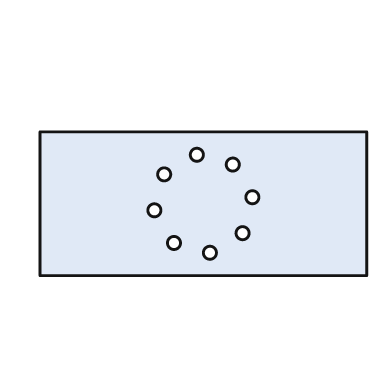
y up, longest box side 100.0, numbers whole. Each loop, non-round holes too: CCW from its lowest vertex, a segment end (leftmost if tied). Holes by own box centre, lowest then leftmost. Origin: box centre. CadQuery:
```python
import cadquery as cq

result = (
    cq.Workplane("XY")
    .moveTo(-50.0, -22.0)
    .lineTo(50.0, -22.0)
    .lineTo(50.0, 22.0)
    .lineTo(-50.0, 22.0)
    .close()
    .moveTo(2.0, -15.0)
    .circle(2.0)
    .moveTo(-9.0, -12.0)
    .circle(2.0)
    .moveTo(12.0, -9.0)
    .circle(2.0)
    .moveTo(-15.0, -2.0)
    .circle(2.0)
    .moveTo(15.0, 2.0)
    .circle(2.0)
    .moveTo(-12.0, 9.0)
    .circle(2.0)
    .moveTo(9.0, 12.0)
    .circle(2.0)
    .moveTo(-2.0, 15.0)
    .circle(2.0)
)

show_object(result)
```